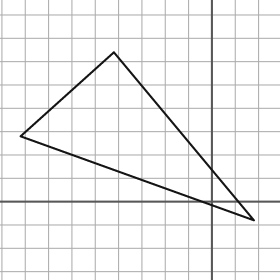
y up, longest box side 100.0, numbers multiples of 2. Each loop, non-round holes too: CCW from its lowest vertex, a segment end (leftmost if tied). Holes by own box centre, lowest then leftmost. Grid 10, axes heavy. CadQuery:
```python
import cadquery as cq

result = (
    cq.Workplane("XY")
    .moveTo(18.0, -8.0)
    .lineTo(-42.0, 64.0)
    .lineTo(-82.0, 28.0)
    .close()
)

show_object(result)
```